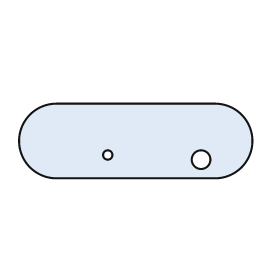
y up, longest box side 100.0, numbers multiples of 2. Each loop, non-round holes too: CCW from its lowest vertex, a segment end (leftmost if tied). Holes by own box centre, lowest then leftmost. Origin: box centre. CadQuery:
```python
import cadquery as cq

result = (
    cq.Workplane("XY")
    .moveTo(-34.0, -16.0)
    .lineTo(34.0, -16.0)
    .threePointArc((50.0, 0.0), (34.0, 16.0))
    .lineTo(-34.0, 16.0)
    .threePointArc((-50.0, 0.0), (-34.0, -16.0))
    .close()
    .moveTo(28.0, -8.0)
    .circle(4.0)
    .moveTo(-12.0, -6.0)
    .circle(2.0)
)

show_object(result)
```